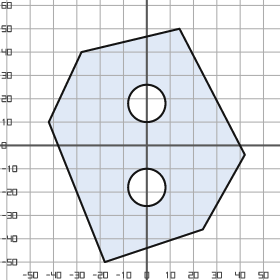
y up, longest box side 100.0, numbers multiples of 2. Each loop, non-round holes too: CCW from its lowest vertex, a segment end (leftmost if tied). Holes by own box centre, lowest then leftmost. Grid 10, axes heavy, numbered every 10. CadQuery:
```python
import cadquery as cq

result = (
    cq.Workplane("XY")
    .moveTo(-18.0, -50.0)
    .lineTo(24.0, -36.0)
    .lineTo(42.0, -4.0)
    .lineTo(14.0, 50.0)
    .lineTo(-28.0, 40.0)
    .lineTo(-42.0, 10.0)
    .close()
    .moveTo(0.0, -18.0)
    .circle(8.0)
    .moveTo(0.0, 18.0)
    .circle(8.0)
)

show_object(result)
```